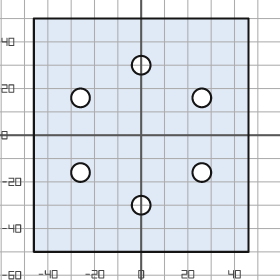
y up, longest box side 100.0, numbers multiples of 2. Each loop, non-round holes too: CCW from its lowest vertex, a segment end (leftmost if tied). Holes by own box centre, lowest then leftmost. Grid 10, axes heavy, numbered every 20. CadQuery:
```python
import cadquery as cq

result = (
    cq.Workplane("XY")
    .moveTo(-46.0, -50.0)
    .lineTo(46.0, -50.0)
    .lineTo(46.0, 50.0)
    .lineTo(-46.0, 50.0)
    .close()
    .moveTo(0.0, -30.0)
    .circle(4.0)
    .moveTo(-26.0, -16.0)
    .circle(4.0)
    .moveTo(26.0, -16.0)
    .circle(4.0)
    .moveTo(-26.0, 16.0)
    .circle(4.0)
    .moveTo(26.0, 16.0)
    .circle(4.0)
    .moveTo(0.0, 30.0)
    .circle(4.0)
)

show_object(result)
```